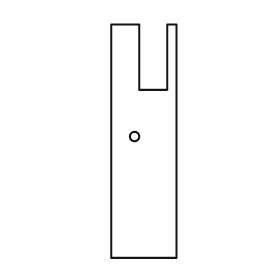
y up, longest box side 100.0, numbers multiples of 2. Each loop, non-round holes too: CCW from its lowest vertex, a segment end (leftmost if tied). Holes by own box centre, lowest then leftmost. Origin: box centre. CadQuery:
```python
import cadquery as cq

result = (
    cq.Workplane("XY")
    .moveTo(-14.0, -50.0)
    .lineTo(14.0, -50.0)
    .lineTo(14.0, 50.0)
    .lineTo(10.0, 50.0)
    .lineTo(10.0, 22.0)
    .lineTo(-2.0, 22.0)
    .lineTo(-2.0, 50.0)
    .lineTo(-14.0, 50.0)
    .close()
    .moveTo(-4.0, 2.0)
    .circle(2.0)
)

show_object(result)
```